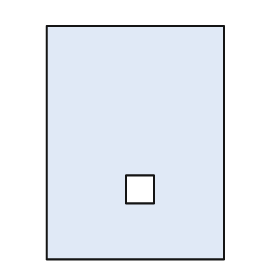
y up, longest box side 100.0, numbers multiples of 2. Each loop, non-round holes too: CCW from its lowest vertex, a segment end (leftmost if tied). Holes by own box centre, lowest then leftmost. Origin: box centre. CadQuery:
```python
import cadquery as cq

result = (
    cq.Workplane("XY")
    .moveTo(-38.0, -50.0)
    .lineTo(38.0, -50.0)
    .lineTo(38.0, 50.0)
    .lineTo(-38.0, 50.0)
    .close()
    .moveTo(-4.0, -26.0)
    .lineTo(8.0, -26.0)
    .lineTo(8.0, -14.0)
    .lineTo(-4.0, -14.0)
    .close()
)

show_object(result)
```